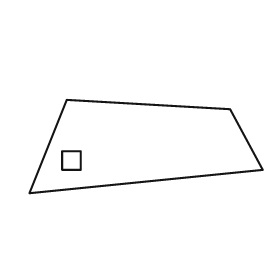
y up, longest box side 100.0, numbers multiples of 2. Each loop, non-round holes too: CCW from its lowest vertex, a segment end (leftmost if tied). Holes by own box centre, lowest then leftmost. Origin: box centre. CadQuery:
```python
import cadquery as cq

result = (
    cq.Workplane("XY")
    .moveTo(-50.0, -20.0)
    .lineTo(50.0, -10.0)
    .lineTo(36.0, 16.0)
    .lineTo(-34.0, 20.0)
    .close()
    .moveTo(-36.0, -10.0)
    .lineTo(-28.0, -10.0)
    .lineTo(-28.0, -2.0)
    .lineTo(-36.0, -2.0)
    .close()
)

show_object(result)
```